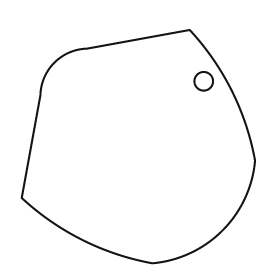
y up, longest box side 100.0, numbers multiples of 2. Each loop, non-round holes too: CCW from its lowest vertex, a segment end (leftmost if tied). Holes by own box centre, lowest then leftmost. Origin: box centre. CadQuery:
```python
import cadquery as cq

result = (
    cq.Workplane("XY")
    .moveTo(6.0, -50.0)
    .threePointArc((36.0, -36.0), (50.0, -6.0))
    .threePointArc((40.0, 24.0), (22.0, 50.0))
    .lineTo(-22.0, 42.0)
    .threePointArc((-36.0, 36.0), (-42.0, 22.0))
    .lineTo(-50.0, -22.0)
    .threePointArc((-24.0, -40.0), (6.0, -50.0))
    .close()
    .moveTo(28.0, 28.0)
    .circle(4.0)
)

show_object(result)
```